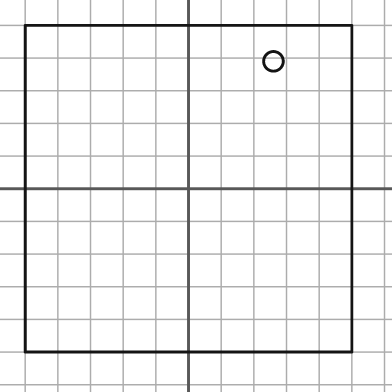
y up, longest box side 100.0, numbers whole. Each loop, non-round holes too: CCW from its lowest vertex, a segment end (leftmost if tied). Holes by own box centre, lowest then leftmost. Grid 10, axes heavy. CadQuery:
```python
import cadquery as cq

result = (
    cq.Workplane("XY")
    .moveTo(-50.0, -50.0)
    .lineTo(50.0, -50.0)
    .lineTo(50.0, 50.0)
    .lineTo(-50.0, 50.0)
    .close()
    .moveTo(26.0, 39.0)
    .circle(3.0)
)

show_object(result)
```